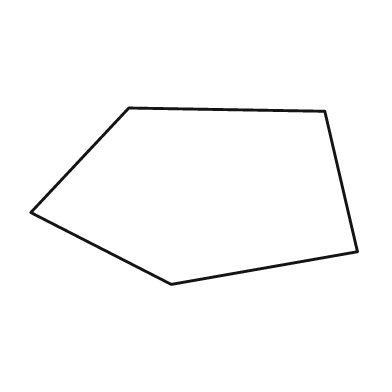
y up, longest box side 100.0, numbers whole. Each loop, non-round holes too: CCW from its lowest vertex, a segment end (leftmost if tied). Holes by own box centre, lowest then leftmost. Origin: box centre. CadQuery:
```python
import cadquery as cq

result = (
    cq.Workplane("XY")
    .moveTo(-7.0, -27.0)
    .lineTo(50.0, -17.0)
    .lineTo(40.0, 26.0)
    .lineTo(-20.0, 27.0)
    .lineTo(-50.0, -5.0)
    .close()
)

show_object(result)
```